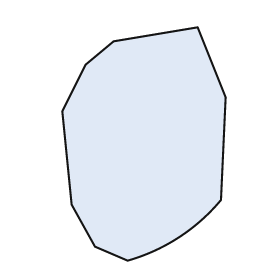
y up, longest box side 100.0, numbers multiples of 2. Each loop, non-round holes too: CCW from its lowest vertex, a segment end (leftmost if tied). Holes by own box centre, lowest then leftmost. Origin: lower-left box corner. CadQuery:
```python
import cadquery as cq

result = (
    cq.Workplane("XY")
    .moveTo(28.0, 0.0)
    .threePointArc((50.0, 10.0), (68.0, 26.0))
    .lineTo(70.0, 70.0)
    .lineTo(58.0, 100.0)
    .lineTo(22.0, 94.0)
    .lineTo(10.0, 84.0)
    .lineTo(0.0, 64.0)
    .lineTo(4.0, 24.0)
    .lineTo(14.0, 6.0)
    .close()
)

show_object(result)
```